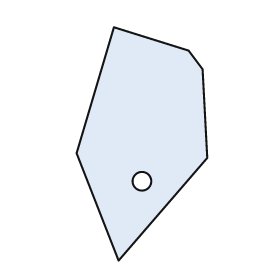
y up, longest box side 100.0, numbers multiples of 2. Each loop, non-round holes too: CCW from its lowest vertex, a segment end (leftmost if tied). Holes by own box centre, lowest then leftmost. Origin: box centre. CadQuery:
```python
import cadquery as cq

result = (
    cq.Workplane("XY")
    .moveTo(-10.0, -50.0)
    .lineTo(28.0, -6.0)
    .lineTo(26.0, 32.0)
    .lineTo(20.0, 40.0)
    .lineTo(-12.0, 50.0)
    .lineTo(-28.0, -4.0)
    .close()
    .moveTo(0.0, -16.0)
    .circle(4.0)
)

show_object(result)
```